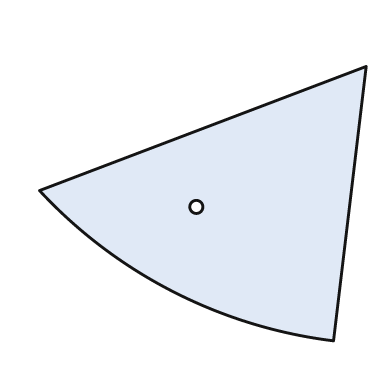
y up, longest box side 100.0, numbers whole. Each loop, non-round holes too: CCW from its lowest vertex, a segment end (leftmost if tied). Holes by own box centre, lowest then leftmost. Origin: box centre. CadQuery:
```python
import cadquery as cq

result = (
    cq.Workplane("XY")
    .moveTo(40.0, -42.0)
    .lineTo(50.0, 42.0)
    .lineTo(-50.0, 4.0)
    .threePointArc((-9.0, -27.0), (40.0, -42.0))
    .close()
    .moveTo(-2.0, -1.0)
    .circle(2.0)
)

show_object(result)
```